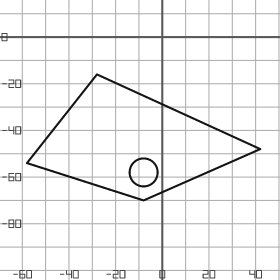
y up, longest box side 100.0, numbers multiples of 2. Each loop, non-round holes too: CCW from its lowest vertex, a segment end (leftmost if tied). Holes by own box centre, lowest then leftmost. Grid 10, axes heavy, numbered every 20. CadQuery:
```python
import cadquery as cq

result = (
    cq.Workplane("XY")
    .moveTo(-8.0, -70.0)
    .lineTo(42.0, -48.0)
    .lineTo(-28.0, -16.0)
    .lineTo(-58.0, -54.0)
    .close()
    .moveTo(-8.0, -58.0)
    .circle(6.0)
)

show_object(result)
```